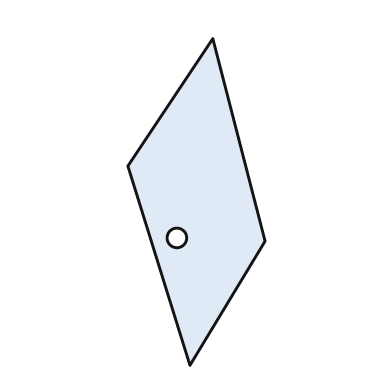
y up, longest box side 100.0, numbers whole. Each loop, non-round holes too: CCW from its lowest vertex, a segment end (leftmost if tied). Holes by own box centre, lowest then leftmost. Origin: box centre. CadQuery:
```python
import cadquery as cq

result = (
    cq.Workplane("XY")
    .moveTo(-2.0, -50.0)
    .lineTo(21.0, -12.0)
    .lineTo(5.0, 50.0)
    .lineTo(-21.0, 11.0)
    .close()
    .moveTo(-6.0, -11.0)
    .circle(3.0)
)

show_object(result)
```